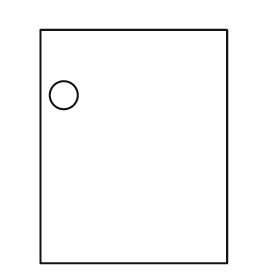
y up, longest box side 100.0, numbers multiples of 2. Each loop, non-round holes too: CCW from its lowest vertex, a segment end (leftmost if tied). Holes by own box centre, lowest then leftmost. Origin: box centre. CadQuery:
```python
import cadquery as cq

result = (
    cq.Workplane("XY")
    .moveTo(-40.0, -50.0)
    .lineTo(40.0, -50.0)
    .lineTo(40.0, 50.0)
    .lineTo(-40.0, 50.0)
    .close()
    .moveTo(-30.0, 22.0)
    .circle(6.0)
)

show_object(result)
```